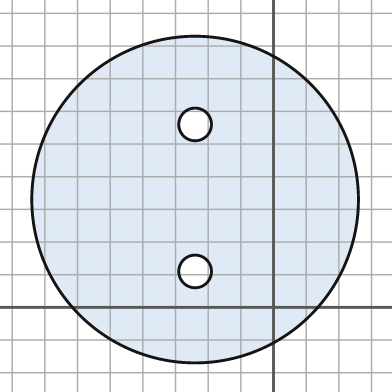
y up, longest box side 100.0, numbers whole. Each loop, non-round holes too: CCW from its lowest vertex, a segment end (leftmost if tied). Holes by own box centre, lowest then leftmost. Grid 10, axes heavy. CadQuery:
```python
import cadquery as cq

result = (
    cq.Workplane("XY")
    .moveTo(-24.0, 33.0)
    .circle(50.0)
    .moveTo(-24.0, 11.0)
    .circle(5.0)
    .moveTo(-24.0, 56.0)
    .circle(5.0)
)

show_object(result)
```